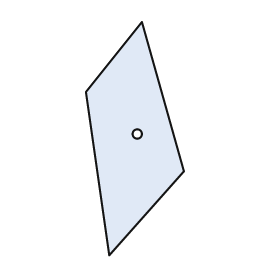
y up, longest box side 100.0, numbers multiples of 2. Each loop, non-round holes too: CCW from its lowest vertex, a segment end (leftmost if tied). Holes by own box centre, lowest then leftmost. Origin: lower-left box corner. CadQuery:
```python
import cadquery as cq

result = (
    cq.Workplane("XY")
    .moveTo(10.0, 0.0)
    .lineTo(42.0, 36.0)
    .lineTo(24.0, 100.0)
    .lineTo(0.0, 70.0)
    .close()
    .moveTo(22.0, 52.0)
    .circle(2.0)
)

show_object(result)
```